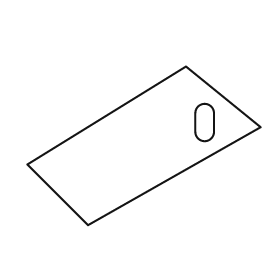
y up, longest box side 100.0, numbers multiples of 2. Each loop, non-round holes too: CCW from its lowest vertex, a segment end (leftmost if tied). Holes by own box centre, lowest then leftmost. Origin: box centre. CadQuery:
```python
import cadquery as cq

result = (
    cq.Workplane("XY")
    .moveTo(-24.0, -34.0)
    .lineTo(50.0, 8.0)
    .lineTo(18.0, 34.0)
    .lineTo(-50.0, -8.0)
    .close()
    .moveTo(22.0, 6.0)
    .threePointArc((26.0, 2.0), (30.0, 6.0))
    .lineTo(30.0, 14.0)
    .threePointArc((26.0, 18.0), (22.0, 14.0))
    .close()
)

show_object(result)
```